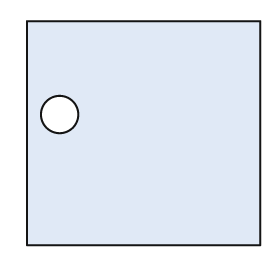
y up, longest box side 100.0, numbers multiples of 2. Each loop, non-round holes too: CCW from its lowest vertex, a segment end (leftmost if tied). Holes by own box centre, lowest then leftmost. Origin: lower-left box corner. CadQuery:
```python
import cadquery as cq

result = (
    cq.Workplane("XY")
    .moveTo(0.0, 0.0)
    .lineTo(100.0, 0.0)
    .lineTo(100.0, 96.0)
    .lineTo(0.0, 96.0)
    .close()
    .moveTo(14.0, 56.0)
    .circle(8.0)
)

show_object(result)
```